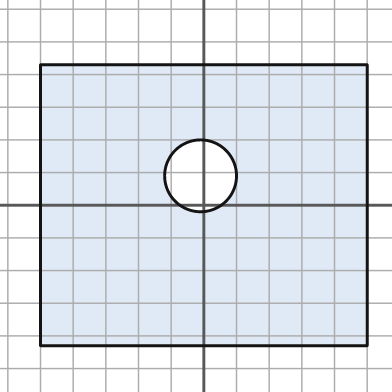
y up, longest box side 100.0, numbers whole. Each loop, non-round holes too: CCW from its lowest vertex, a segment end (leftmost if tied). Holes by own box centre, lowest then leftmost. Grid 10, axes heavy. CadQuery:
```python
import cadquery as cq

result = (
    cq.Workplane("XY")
    .moveTo(-50.0, -43.0)
    .lineTo(50.0, -43.0)
    .lineTo(50.0, 43.0)
    .lineTo(-50.0, 43.0)
    .close()
    .moveTo(-1.0, 9.0)
    .circle(11.0)
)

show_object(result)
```